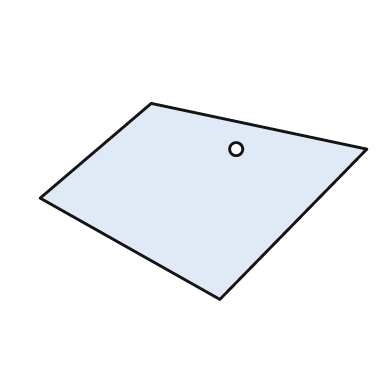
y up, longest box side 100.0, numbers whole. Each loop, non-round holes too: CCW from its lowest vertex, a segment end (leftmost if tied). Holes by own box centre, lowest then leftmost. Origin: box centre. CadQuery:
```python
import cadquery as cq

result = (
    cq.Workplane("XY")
    .moveTo(5.0, -30.0)
    .lineTo(50.0, 16.0)
    .lineTo(-16.0, 30.0)
    .lineTo(-50.0, 1.0)
    .close()
    .moveTo(10.0, 16.0)
    .circle(2.0)
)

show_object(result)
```